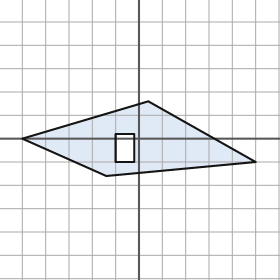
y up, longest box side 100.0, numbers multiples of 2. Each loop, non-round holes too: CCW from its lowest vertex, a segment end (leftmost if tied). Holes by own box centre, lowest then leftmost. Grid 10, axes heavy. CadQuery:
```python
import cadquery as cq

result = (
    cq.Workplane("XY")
    .moveTo(-14.0, -16.0)
    .lineTo(50.0, -10.0)
    .lineTo(4.0, 16.0)
    .lineTo(-50.0, 0.0)
    .close()
    .moveTo(-10.0, -10.0)
    .lineTo(-2.0, -10.0)
    .lineTo(-2.0, 2.0)
    .lineTo(-10.0, 2.0)
    .close()
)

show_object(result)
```